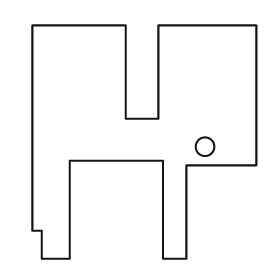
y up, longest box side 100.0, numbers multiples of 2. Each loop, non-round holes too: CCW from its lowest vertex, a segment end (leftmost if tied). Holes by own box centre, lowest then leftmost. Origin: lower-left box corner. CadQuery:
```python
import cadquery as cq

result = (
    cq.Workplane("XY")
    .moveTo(4.0, 0.0)
    .lineTo(16.0, 0.0)
    .lineTo(16.0, 42.0)
    .lineTo(56.0, 42.0)
    .lineTo(56.0, 0.0)
    .lineTo(66.0, 0.0)
    .lineTo(66.0, 40.0)
    .lineTo(96.0, 40.0)
    .lineTo(96.0, 100.0)
    .lineTo(54.0, 100.0)
    .lineTo(54.0, 60.0)
    .lineTo(40.0, 60.0)
    .lineTo(40.0, 100.0)
    .lineTo(0.0, 100.0)
    .lineTo(0.0, 12.0)
    .lineTo(4.0, 12.0)
    .close()
    .moveTo(74.0, 48.0)
    .circle(4.0)
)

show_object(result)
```